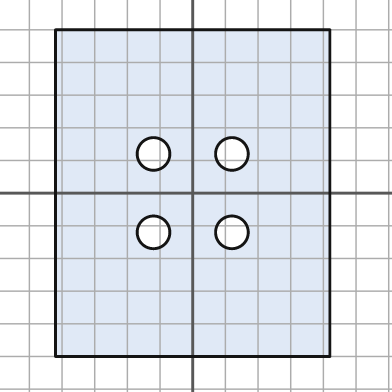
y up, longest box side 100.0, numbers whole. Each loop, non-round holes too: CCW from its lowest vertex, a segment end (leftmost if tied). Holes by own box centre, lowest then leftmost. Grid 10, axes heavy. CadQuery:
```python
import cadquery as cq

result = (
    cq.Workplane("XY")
    .moveTo(-42.0, -50.0)
    .lineTo(42.0, -50.0)
    .lineTo(42.0, 50.0)
    .lineTo(-42.0, 50.0)
    .close()
    .moveTo(-12.0, -12.0)
    .circle(5.0)
    .moveTo(12.0, -12.0)
    .circle(5.0)
    .moveTo(-12.0, 12.0)
    .circle(5.0)
    .moveTo(12.0, 12.0)
    .circle(5.0)
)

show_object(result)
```